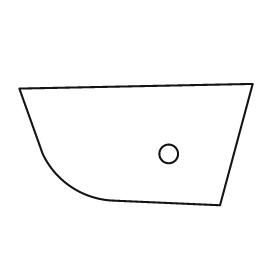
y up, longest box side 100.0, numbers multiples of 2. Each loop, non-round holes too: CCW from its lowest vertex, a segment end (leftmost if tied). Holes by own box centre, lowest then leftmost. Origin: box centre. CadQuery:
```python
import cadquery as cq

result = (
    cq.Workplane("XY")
    .moveTo(36.0, -26.0)
    .lineTo(50.0, 26.0)
    .lineTo(-50.0, 24.0)
    .lineTo(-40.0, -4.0)
    .threePointArc((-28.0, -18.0), (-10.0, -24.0))
    .close()
    .moveTo(14.0, -4.0)
    .circle(4.0)
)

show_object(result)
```